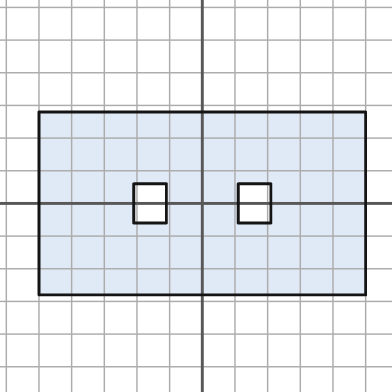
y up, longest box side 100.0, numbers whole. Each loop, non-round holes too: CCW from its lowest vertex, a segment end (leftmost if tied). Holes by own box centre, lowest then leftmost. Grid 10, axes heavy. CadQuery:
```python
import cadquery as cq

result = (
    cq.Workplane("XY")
    .moveTo(-50.0, -28.0)
    .lineTo(50.0, -28.0)
    .lineTo(50.0, 28.0)
    .lineTo(-50.0, 28.0)
    .close()
    .moveTo(-21.0, -6.0)
    .lineTo(-11.0, -6.0)
    .lineTo(-11.0, 6.0)
    .lineTo(-21.0, 6.0)
    .close()
    .moveTo(11.0, -6.0)
    .lineTo(21.0, -6.0)
    .lineTo(21.0, 6.0)
    .lineTo(11.0, 6.0)
    .close()
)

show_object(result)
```